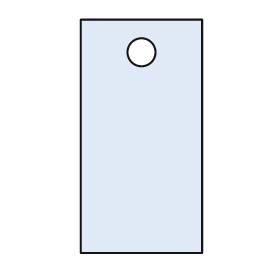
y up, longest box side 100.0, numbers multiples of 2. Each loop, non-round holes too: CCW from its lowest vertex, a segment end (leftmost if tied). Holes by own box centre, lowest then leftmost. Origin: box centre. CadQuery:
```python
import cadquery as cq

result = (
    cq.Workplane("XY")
    .moveTo(-26.0, -50.0)
    .lineTo(26.0, -50.0)
    .lineTo(26.0, 50.0)
    .lineTo(-26.0, 50.0)
    .close()
    .moveTo(0.0, 36.0)
    .circle(6.0)
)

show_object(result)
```